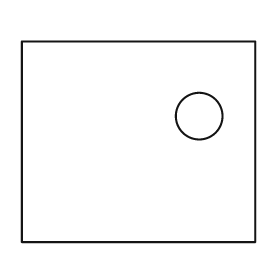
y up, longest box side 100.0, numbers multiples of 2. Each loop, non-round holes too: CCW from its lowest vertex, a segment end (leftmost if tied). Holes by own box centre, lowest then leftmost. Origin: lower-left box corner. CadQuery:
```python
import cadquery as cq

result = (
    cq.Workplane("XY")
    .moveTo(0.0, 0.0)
    .lineTo(100.0, 0.0)
    .lineTo(100.0, 86.0)
    .lineTo(0.0, 86.0)
    .close()
    .moveTo(76.0, 54.0)
    .circle(10.0)
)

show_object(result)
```